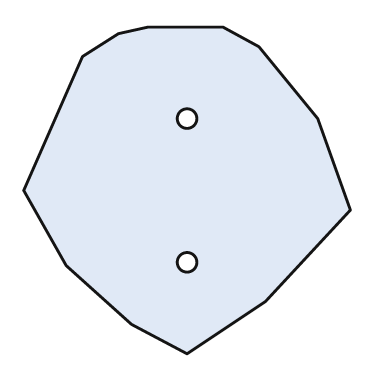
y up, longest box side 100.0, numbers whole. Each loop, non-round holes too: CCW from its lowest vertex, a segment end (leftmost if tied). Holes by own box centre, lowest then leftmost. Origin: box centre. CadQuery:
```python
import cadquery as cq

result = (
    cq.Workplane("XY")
    .moveTo(0.0, -50.0)
    .lineTo(24.0, -34.0)
    .lineTo(50.0, -6.0)
    .lineTo(40.0, 22.0)
    .lineTo(22.0, 44.0)
    .lineTo(11.0, 50.0)
    .lineTo(-12.0, 50.0)
    .lineTo(-21.0, 48.0)
    .lineTo(-32.0, 41.0)
    .lineTo(-50.0, 0.0)
    .lineTo(-37.0, -23.0)
    .lineTo(-17.0, -41.0)
    .close()
    .moveTo(0.0, -22.0)
    .circle(3.0)
    .moveTo(0.0, 22.0)
    .circle(3.0)
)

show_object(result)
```